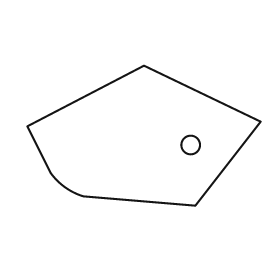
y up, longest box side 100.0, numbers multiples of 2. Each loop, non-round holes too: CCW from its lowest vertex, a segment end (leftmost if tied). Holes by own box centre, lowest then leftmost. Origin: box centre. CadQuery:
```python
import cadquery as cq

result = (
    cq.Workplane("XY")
    .moveTo(22.0, -30.0)
    .lineTo(50.0, 6.0)
    .lineTo(0.0, 30.0)
    .lineTo(-50.0, 4.0)
    .lineTo(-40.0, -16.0)
    .threePointArc((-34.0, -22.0), (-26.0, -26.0))
    .close()
    .moveTo(20.0, -4.0)
    .circle(4.0)
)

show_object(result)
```